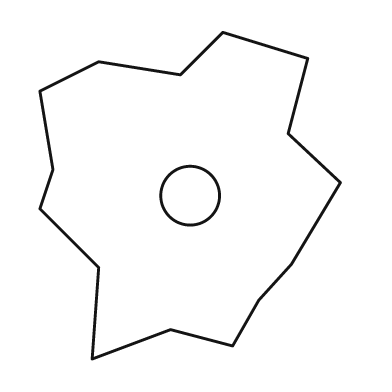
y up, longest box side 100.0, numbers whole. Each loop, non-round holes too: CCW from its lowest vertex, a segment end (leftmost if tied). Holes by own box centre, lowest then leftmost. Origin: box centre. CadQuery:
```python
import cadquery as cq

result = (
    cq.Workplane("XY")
    .moveTo(-30.0, -50.0)
    .lineTo(-6.0, -41.0)
    .lineTo(13.0, -46.0)
    .lineTo(21.0, -32.0)
    .lineTo(31.0, -21.0)
    .lineTo(46.0, 4.0)
    .lineTo(30.0, 19.0)
    .lineTo(36.0, 42.0)
    .lineTo(10.0, 50.0)
    .lineTo(-3.0, 37.0)
    .lineTo(-28.0, 41.0)
    .lineTo(-46.0, 32.0)
    .lineTo(-42.0, 8.0)
    .lineTo(-46.0, -4.0)
    .lineTo(-28.0, -22.0)
    .close()
    .moveTo(0.0, 0.0)
    .circle(9.0)
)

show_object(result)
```